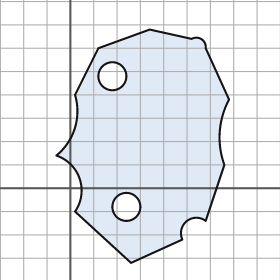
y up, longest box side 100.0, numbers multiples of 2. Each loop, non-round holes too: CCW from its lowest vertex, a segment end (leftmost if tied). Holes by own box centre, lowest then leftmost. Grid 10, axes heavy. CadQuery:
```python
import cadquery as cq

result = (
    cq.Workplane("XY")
    .moveTo(26.0, -32.0)
    .lineTo(48.0, -22.0)
    .threePointArc((50.0, -14.0), (58.0, -14.0))
    .lineTo(66.0, 10.0)
    .threePointArc((64.0, 24.0), (68.0, 38.0))
    .lineTo(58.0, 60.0)
    .threePointArc((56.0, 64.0), (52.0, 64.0))
    .lineTo(34.0, 68.0)
    .lineTo(12.0, 60.0)
    .lineTo(2.0, 40.0)
    .threePointArc((2.0, 26.0), (-6.0, 14.0))
    .threePointArc((4.0, 4.0), (2.0, -10.0))
    .close()
    .moveTo(24.0, -8.0)
    .circle(6.0)
    .moveTo(18.0, 48.0)
    .circle(6.0)
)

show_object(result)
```